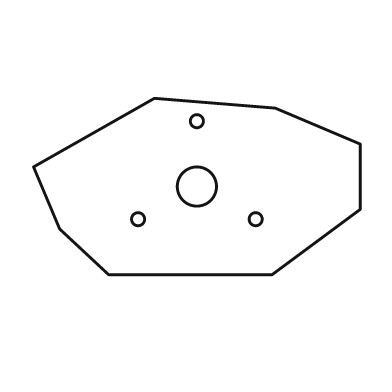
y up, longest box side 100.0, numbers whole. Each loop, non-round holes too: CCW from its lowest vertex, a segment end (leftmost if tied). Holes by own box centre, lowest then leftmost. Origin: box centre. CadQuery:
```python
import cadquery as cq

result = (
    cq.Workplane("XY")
    .moveTo(-27.0, -27.0)
    .lineTo(23.0, -27.0)
    .lineTo(50.0, -7.0)
    .lineTo(50.0, 13.0)
    .lineTo(24.0, 24.0)
    .lineTo(-13.0, 27.0)
    .lineTo(-50.0, 6.0)
    .lineTo(-42.0, -13.0)
    .close()
    .moveTo(-18.0, -10.0)
    .circle(2.0)
    .moveTo(18.0, -10.0)
    .circle(2.0)
    .moveTo(0.0, 0.0)
    .circle(6.0)
    .moveTo(0.0, 20.0)
    .circle(2.0)
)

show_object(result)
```